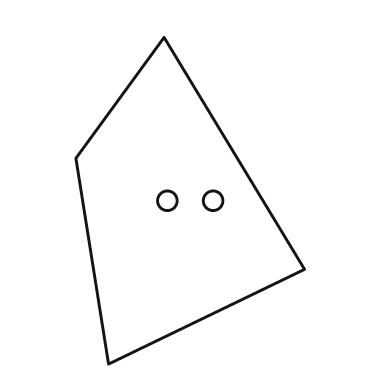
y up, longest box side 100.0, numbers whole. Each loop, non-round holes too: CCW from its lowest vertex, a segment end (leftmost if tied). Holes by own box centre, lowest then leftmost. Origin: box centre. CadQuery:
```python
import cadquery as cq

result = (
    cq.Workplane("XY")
    .moveTo(-25.0, -50.0)
    .lineTo(35.0, -21.0)
    .lineTo(-8.0, 50.0)
    .lineTo(-35.0, 13.0)
    .close()
    .moveTo(-7.0, 0.0)
    .circle(3.0)
    .moveTo(7.0, 0.0)
    .circle(3.0)
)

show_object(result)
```